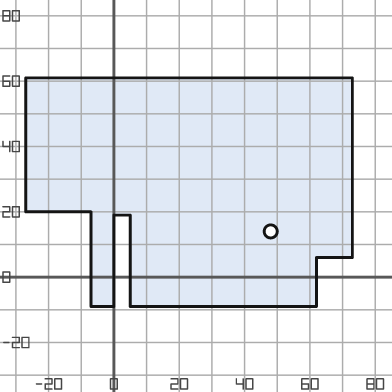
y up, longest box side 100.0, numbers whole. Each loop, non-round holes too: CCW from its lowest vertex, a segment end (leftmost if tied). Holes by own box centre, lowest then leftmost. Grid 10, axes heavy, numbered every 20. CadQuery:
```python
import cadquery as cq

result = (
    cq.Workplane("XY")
    .moveTo(-7.0, -9.0)
    .lineTo(0.0, -9.0)
    .lineTo(0.0, 19.0)
    .lineTo(5.0, 19.0)
    .lineTo(5.0, -9.0)
    .lineTo(62.0, -9.0)
    .lineTo(62.0, 6.0)
    .lineTo(73.0, 6.0)
    .lineTo(73.0, 61.0)
    .lineTo(-27.0, 61.0)
    .lineTo(-27.0, 20.0)
    .lineTo(-7.0, 20.0)
    .close()
    .moveTo(48.0, 14.0)
    .circle(2.0)
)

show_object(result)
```